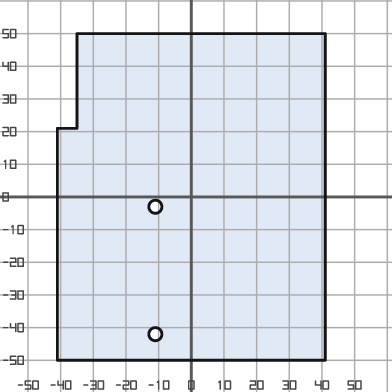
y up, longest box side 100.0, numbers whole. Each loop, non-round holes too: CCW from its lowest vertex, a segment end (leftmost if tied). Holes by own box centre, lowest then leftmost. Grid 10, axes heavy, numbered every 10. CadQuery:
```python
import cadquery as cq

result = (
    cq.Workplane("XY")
    .moveTo(-41.0, -50.0)
    .lineTo(41.0, -50.0)
    .lineTo(41.0, 50.0)
    .lineTo(-35.0, 50.0)
    .lineTo(-35.0, 21.0)
    .lineTo(-41.0, 21.0)
    .close()
    .moveTo(-11.0, -42.0)
    .circle(2.0)
    .moveTo(-11.0, -3.0)
    .circle(2.0)
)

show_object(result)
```